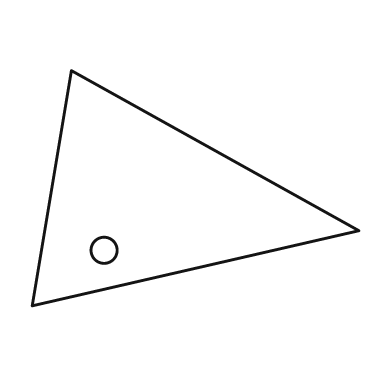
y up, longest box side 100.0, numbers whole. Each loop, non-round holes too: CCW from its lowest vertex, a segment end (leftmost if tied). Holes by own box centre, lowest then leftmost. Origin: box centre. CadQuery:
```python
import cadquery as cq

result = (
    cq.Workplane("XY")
    .moveTo(-50.0, -36.0)
    .lineTo(50.0, -13.0)
    .lineTo(-38.0, 36.0)
    .close()
    .moveTo(-28.0, -19.0)
    .circle(4.0)
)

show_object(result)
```